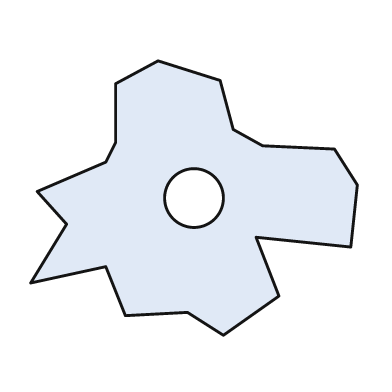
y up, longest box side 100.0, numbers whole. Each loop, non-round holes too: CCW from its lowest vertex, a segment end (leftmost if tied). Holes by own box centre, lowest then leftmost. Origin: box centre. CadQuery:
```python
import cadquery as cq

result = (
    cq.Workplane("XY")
    .moveTo(9.0, -42.0)
    .lineTo(26.0, -30.0)
    .lineTo(19.0, -12.0)
    .lineTo(48.0, -15.0)
    .lineTo(50.0, 4.0)
    .lineTo(43.0, 15.0)
    .lineTo(21.0, 16.0)
    .lineTo(12.0, 21.0)
    .lineTo(8.0, 36.0)
    .lineTo(-11.0, 42.0)
    .lineTo(-24.0, 35.0)
    .lineTo(-24.0, 17.0)
    .lineTo(-27.0, 11.0)
    .lineTo(-48.0, 2.0)
    .lineTo(-39.0, -8.0)
    .lineTo(-50.0, -26.0)
    .lineTo(-27.0, -21.0)
    .lineTo(-21.0, -36.0)
    .lineTo(-2.0, -35.0)
    .close()
    .moveTo(0.0, 0.0)
    .circle(9.0)
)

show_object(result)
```